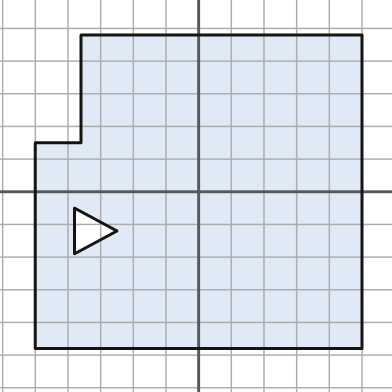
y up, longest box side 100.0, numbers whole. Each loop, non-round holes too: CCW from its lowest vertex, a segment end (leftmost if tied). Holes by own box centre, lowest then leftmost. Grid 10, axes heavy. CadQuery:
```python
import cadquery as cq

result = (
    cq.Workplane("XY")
    .moveTo(-50.0, -48.0)
    .lineTo(50.0, -48.0)
    .lineTo(50.0, 48.0)
    .lineTo(-36.0, 48.0)
    .lineTo(-36.0, 15.0)
    .lineTo(-50.0, 15.0)
    .close()
    .moveTo(-38.0, -19.0)
    .lineTo(-25.0, -12.0)
    .lineTo(-38.0, -5.0)
    .close()
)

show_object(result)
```